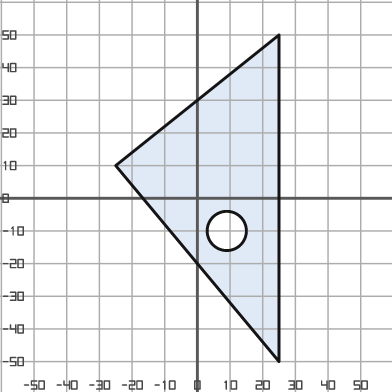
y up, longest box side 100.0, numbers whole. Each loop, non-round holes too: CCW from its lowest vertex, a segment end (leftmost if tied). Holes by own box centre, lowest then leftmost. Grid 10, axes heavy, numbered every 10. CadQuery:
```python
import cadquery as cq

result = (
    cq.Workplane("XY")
    .moveTo(25.0, -50.0)
    .lineTo(25.0, 50.0)
    .lineTo(-25.0, 10.0)
    .close()
    .moveTo(9.0, -10.0)
    .circle(6.0)
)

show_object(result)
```